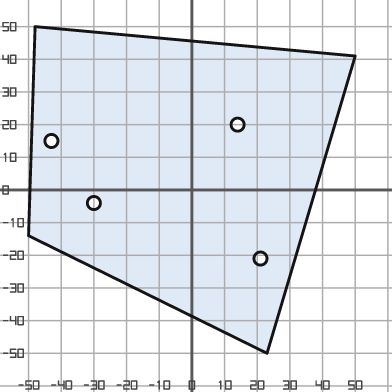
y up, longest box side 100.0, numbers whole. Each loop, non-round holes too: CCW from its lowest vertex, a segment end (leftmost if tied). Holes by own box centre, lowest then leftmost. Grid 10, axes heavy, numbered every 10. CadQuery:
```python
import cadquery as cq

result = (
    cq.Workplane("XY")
    .moveTo(23.0, -50.0)
    .lineTo(50.0, 41.0)
    .lineTo(-48.0, 50.0)
    .lineTo(-50.0, -14.0)
    .close()
    .moveTo(21.0, -21.0)
    .circle(2.0)
    .moveTo(-30.0, -4.0)
    .circle(2.0)
    .moveTo(-43.0, 15.0)
    .circle(2.0)
    .moveTo(14.0, 20.0)
    .circle(2.0)
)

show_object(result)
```